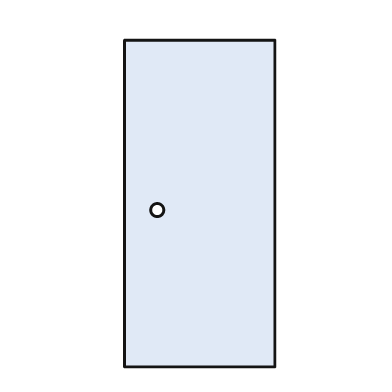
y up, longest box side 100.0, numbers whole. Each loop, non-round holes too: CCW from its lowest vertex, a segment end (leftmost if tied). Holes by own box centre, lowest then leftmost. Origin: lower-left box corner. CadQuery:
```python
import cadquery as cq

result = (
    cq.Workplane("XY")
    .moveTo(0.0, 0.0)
    .lineTo(46.0, 0.0)
    .lineTo(46.0, 100.0)
    .lineTo(0.0, 100.0)
    .close()
    .moveTo(10.0, 48.0)
    .circle(2.0)
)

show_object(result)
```